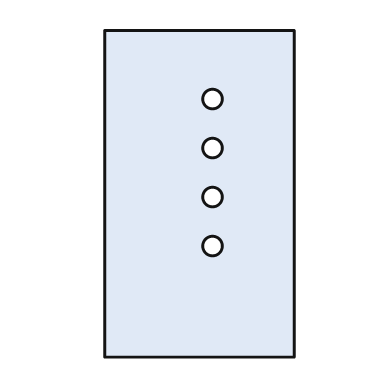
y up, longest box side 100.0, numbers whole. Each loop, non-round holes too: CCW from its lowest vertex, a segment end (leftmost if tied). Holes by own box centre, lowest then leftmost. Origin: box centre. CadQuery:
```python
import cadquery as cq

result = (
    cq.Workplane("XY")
    .moveTo(-29.0, -50.0)
    .lineTo(29.0, -50.0)
    .lineTo(29.0, 50.0)
    .lineTo(-29.0, 50.0)
    .close()
    .moveTo(4.0, -16.0)
    .circle(3.0)
    .moveTo(4.0, -1.0)
    .circle(3.0)
    .moveTo(4.0, 14.0)
    .circle(3.0)
    .moveTo(4.0, 29.0)
    .circle(3.0)
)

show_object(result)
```